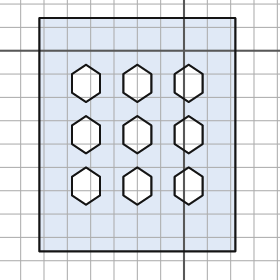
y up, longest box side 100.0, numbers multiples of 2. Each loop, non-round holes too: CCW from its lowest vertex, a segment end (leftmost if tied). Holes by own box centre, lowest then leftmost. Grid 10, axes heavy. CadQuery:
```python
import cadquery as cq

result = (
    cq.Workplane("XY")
    .moveTo(-62.0, -86.0)
    .lineTo(22.0, -86.0)
    .lineTo(22.0, 14.0)
    .lineTo(-62.0, 14.0)
    .close()
    .moveTo(-42.0, -66.0)
    .lineTo(-36.0, -62.0)
    .lineTo(-36.0, -54.0)
    .lineTo(-42.0, -50.0)
    .lineTo(-48.0, -54.0)
    .lineTo(-48.0, -62.0)
    .close()
    .moveTo(-20.0, -66.0)
    .lineTo(-14.0, -62.0)
    .lineTo(-14.0, -54.0)
    .lineTo(-20.0, -50.0)
    .lineTo(-26.0, -54.0)
    .lineTo(-26.0, -62.0)
    .close()
    .moveTo(2.0, -66.0)
    .lineTo(8.0, -62.0)
    .lineTo(8.0, -54.0)
    .lineTo(2.0, -50.0)
    .lineTo(-4.0, -54.0)
    .lineTo(-4.0, -62.0)
    .close()
    .moveTo(-42.0, -44.0)
    .lineTo(-36.0, -40.0)
    .lineTo(-36.0, -32.0)
    .lineTo(-42.0, -28.0)
    .lineTo(-48.0, -32.0)
    .lineTo(-48.0, -40.0)
    .close()
    .moveTo(-20.0, -44.0)
    .lineTo(-14.0, -40.0)
    .lineTo(-14.0, -32.0)
    .lineTo(-20.0, -28.0)
    .lineTo(-26.0, -32.0)
    .lineTo(-26.0, -40.0)
    .close()
    .moveTo(2.0, -44.0)
    .lineTo(8.0, -40.0)
    .lineTo(8.0, -32.0)
    .lineTo(2.0, -28.0)
    .lineTo(-4.0, -32.0)
    .lineTo(-4.0, -40.0)
    .close()
    .moveTo(-42.0, -22.0)
    .lineTo(-36.0, -18.0)
    .lineTo(-36.0, -10.0)
    .lineTo(-42.0, -6.0)
    .lineTo(-48.0, -10.0)
    .lineTo(-48.0, -18.0)
    .close()
    .moveTo(-20.0, -22.0)
    .lineTo(-14.0, -18.0)
    .lineTo(-14.0, -10.0)
    .lineTo(-20.0, -6.0)
    .lineTo(-26.0, -10.0)
    .lineTo(-26.0, -18.0)
    .close()
    .moveTo(2.0, -22.0)
    .lineTo(8.0, -18.0)
    .lineTo(8.0, -10.0)
    .lineTo(2.0, -6.0)
    .lineTo(-4.0, -10.0)
    .lineTo(-4.0, -18.0)
    .close()
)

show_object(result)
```